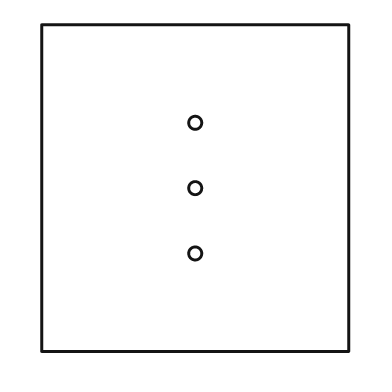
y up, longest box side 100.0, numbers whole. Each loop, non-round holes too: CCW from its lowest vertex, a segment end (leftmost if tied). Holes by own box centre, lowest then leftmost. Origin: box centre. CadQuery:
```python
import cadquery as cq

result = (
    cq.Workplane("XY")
    .moveTo(-47.0, -50.0)
    .lineTo(47.0, -50.0)
    .lineTo(47.0, 50.0)
    .lineTo(-47.0, 50.0)
    .close()
    .moveTo(0.0, -20.0)
    .circle(2.0)
    .moveTo(0.0, 0.0)
    .circle(2.0)
    .moveTo(0.0, 20.0)
    .circle(2.0)
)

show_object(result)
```